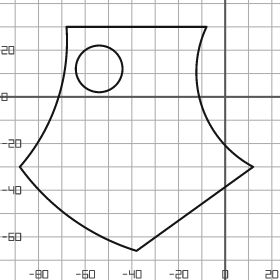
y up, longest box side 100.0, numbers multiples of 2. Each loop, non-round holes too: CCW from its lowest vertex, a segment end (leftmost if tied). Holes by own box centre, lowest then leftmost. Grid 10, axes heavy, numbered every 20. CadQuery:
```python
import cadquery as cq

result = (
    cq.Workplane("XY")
    .moveTo(-38.0, -66.0)
    .lineTo(12.0, -30.0)
    .threePointArc((-10.0, -4.0), (-8.0, 30.0))
    .lineTo(-68.0, 30.0)
    .threePointArc((-72.0, -2.0), (-88.0, -30.0))
    .threePointArc((-66.0, -52.0), (-38.0, -66.0))
    .close()
    .moveTo(-54.0, 12.0)
    .circle(10.0)
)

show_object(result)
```